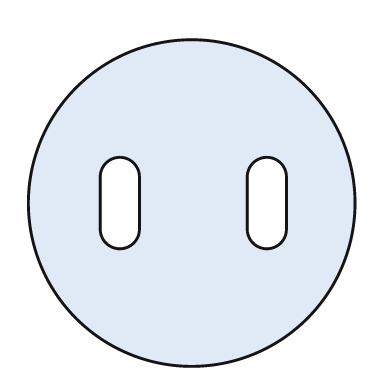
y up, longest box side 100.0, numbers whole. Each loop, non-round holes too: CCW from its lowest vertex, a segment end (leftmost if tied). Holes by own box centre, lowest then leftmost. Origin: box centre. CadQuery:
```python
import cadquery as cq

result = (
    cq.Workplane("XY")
    .moveTo(0.0, 0.0)
    .circle(50.0)
    .moveTo(-28.0, -8.0)
    .threePointArc((-22.0, -14.0), (-16.0, -8.0))
    .lineTo(-16.0, 8.0)
    .threePointArc((-22.0, 14.0), (-28.0, 8.0))
    .close()
    .moveTo(17.0, -8.0)
    .threePointArc((23.0, -14.0), (29.0, -8.0))
    .lineTo(29.0, 8.0)
    .threePointArc((23.0, 14.0), (17.0, 8.0))
    .close()
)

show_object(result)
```